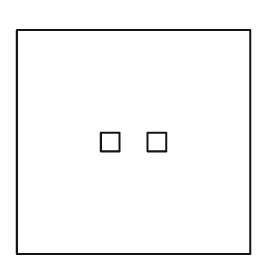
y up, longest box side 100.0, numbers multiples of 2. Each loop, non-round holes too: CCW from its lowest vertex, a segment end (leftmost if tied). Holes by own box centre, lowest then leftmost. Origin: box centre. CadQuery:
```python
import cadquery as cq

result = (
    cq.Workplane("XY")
    .moveTo(-50.0, -48.0)
    .lineTo(50.0, -48.0)
    .lineTo(50.0, 48.0)
    .lineTo(-50.0, 48.0)
    .close()
    .moveTo(-14.0, -4.0)
    .lineTo(-6.0, -4.0)
    .lineTo(-6.0, 4.0)
    .lineTo(-14.0, 4.0)
    .close()
    .moveTo(6.0, -4.0)
    .lineTo(14.0, -4.0)
    .lineTo(14.0, 4.0)
    .lineTo(6.0, 4.0)
    .close()
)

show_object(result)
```